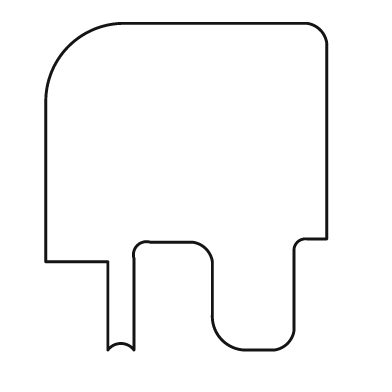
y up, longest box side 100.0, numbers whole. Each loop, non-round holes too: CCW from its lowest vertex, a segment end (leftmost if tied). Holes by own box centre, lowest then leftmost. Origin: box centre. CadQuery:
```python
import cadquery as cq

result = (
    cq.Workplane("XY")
    .moveTo(-24.0, -50.0)
    .threePointArc((-20.0, -48.0), (-16.0, -50.0))
    .lineTo(-16.0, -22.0)
    .threePointArc((-15.0, -18.0), (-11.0, -17.0))
    .lineTo(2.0, -17.0)
    .threePointArc((6.0, -19.0), (8.0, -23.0))
    .lineTo(8.0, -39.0)
    .threePointArc((11.0, -47.0), (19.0, -50.0))
    .lineTo(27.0, -50.0)
    .threePointArc((31.0, -48.0), (33.0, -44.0))
    .lineTo(33.0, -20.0)
    .threePointArc((34.0, -17.0), (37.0, -16.0))
    .lineTo(43.0, -16.0)
    .lineTo(43.0, 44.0)
    .threePointArc((41.0, 48.0), (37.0, 50.0))
    .lineTo(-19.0, 50.0)
    .threePointArc((-36.0, 43.0), (-43.0, 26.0))
    .lineTo(-43.0, -23.0)
    .lineTo(-24.0, -23.0)
    .close()
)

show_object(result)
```